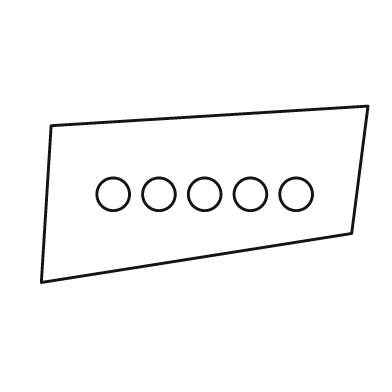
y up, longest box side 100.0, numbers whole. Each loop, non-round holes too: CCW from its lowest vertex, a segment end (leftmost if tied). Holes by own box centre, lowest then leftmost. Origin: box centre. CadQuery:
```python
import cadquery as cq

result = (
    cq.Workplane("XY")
    .moveTo(-50.0, -27.0)
    .lineTo(45.0, -12.0)
    .lineTo(50.0, 27.0)
    .lineTo(-47.0, 21.0)
    .close()
    .moveTo(-28.0, 0.0)
    .circle(5.0)
    .moveTo(-14.0, 0.0)
    .circle(5.0)
    .moveTo(0.0, 0.0)
    .circle(5.0)
    .moveTo(14.0, 0.0)
    .circle(5.0)
    .moveTo(28.0, 0.0)
    .circle(5.0)
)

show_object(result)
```